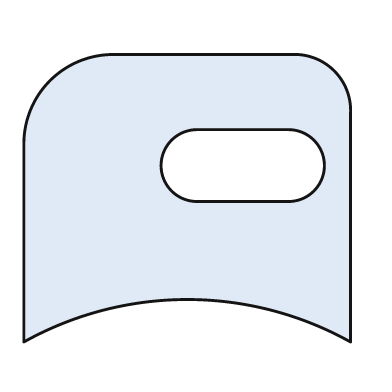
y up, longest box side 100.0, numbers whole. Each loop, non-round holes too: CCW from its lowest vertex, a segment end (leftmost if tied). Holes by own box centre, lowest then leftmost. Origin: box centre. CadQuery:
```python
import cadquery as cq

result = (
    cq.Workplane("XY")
    .moveTo(-50.0, -44.0)
    .threePointArc((0.0, -31.0), (50.0, -44.0))
    .lineTo(50.0, 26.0)
    .threePointArc((45.0, 39.0), (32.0, 44.0))
    .lineTo(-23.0, 44.0)
    .threePointArc((-42.0, 36.0), (-50.0, 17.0))
    .close()
    .moveTo(3.0, -1.0)
    .lineTo(31.0, -1.0)
    .threePointArc((42.0, 10.0), (31.0, 21.0))
    .lineTo(3.0, 21.0)
    .threePointArc((-8.0, 10.0), (3.0, -1.0))
    .close()
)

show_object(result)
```